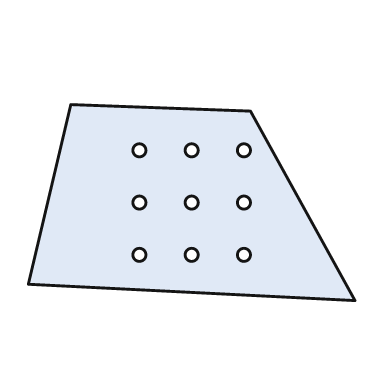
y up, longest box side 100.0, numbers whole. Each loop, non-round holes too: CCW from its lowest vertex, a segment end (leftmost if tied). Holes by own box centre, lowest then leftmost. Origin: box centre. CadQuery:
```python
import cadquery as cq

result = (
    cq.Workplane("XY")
    .moveTo(50.0, -30.0)
    .lineTo(18.0, 28.0)
    .lineTo(-37.0, 30.0)
    .lineTo(-50.0, -25.0)
    .close()
    .moveTo(-16.0, -16.0)
    .circle(2.0)
    .moveTo(0.0, -16.0)
    .circle(2.0)
    .moveTo(16.0, -16.0)
    .circle(2.0)
    .moveTo(-16.0, 0.0)
    .circle(2.0)
    .moveTo(0.0, 0.0)
    .circle(2.0)
    .moveTo(16.0, 0.0)
    .circle(2.0)
    .moveTo(-16.0, 16.0)
    .circle(2.0)
    .moveTo(0.0, 16.0)
    .circle(2.0)
    .moveTo(16.0, 16.0)
    .circle(2.0)
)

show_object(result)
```